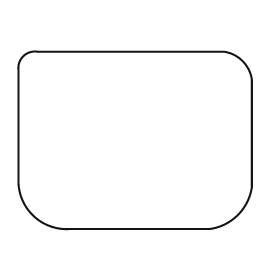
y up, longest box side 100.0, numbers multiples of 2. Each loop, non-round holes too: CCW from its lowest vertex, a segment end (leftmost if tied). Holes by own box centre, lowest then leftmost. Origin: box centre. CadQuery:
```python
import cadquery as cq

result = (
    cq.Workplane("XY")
    .moveTo(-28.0, -38.0)
    .lineTo(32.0, -38.0)
    .threePointArc((44.0, -32.0), (50.0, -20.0))
    .lineTo(50.0, 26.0)
    .threePointArc((46.0, 34.0), (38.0, 38.0))
    .lineTo(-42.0, 38.0)
    .threePointArc((-48.0, 36.0), (-50.0, 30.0))
    .lineTo(-50.0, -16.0)
    .threePointArc((-44.0, -32.0), (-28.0, -38.0))
    .close()
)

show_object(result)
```